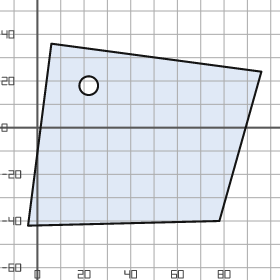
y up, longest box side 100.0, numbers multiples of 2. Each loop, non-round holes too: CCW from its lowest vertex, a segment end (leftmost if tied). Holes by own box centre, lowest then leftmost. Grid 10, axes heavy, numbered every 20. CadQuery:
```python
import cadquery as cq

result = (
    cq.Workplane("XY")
    .moveTo(-4.0, -42.0)
    .lineTo(78.0, -40.0)
    .lineTo(96.0, 24.0)
    .lineTo(6.0, 36.0)
    .close()
    .moveTo(22.0, 18.0)
    .circle(4.0)
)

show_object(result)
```